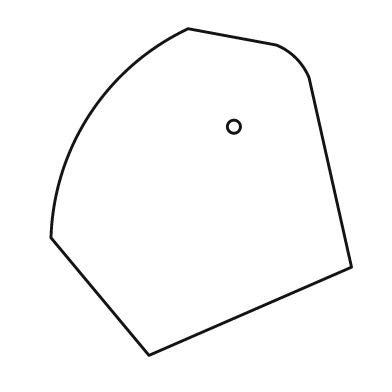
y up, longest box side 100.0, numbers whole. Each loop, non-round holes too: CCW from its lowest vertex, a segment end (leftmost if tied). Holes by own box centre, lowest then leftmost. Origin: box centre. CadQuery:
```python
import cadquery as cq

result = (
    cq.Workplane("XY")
    .moveTo(-16.0, -50.0)
    .lineTo(46.0, -23.0)
    .lineTo(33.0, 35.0)
    .threePointArc((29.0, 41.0), (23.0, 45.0))
    .lineTo(-4.0, 50.0)
    .threePointArc((-34.0, 24.0), (-46.0, -14.0))
    .close()
    .moveTo(10.0, 20.0)
    .circle(2.0)
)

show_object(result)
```